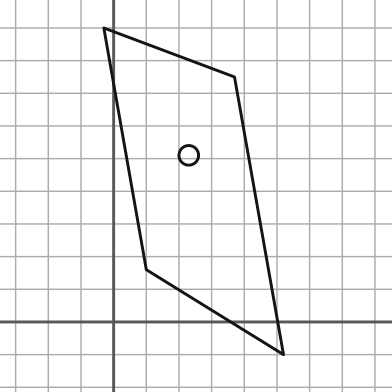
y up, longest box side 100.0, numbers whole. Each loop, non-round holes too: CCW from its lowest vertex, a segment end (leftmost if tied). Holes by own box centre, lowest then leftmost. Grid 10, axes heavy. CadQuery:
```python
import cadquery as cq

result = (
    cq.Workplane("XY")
    .moveTo(52.0, -10.0)
    .lineTo(37.0, 75.0)
    .lineTo(-3.0, 90.0)
    .lineTo(10.0, 16.0)
    .close()
    .moveTo(23.0, 51.0)
    .circle(3.0)
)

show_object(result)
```